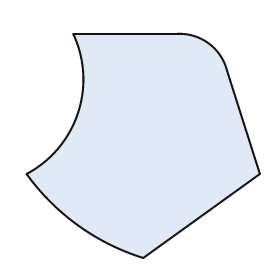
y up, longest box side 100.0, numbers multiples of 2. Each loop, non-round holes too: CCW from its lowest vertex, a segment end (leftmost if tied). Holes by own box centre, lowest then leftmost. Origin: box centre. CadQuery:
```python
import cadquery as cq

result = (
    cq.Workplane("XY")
    .moveTo(0.0, -48.0)
    .lineTo(50.0, -12.0)
    .lineTo(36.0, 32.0)
    .threePointArc((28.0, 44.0), (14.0, 48.0))
    .lineTo(-30.0, 48.0)
    .threePointArc((-28.0, 14.0), (-50.0, -12.0))
    .threePointArc((-28.0, -34.0), (0.0, -48.0))
    .close()
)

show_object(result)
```